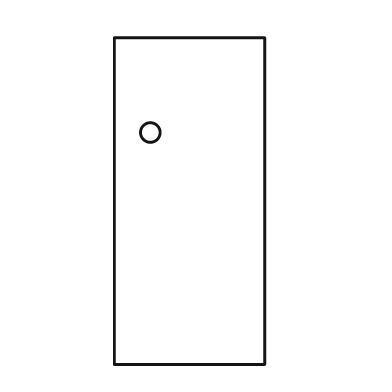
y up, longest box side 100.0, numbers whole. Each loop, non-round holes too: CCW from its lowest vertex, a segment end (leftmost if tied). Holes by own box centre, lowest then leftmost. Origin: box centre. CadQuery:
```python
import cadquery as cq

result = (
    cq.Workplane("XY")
    .moveTo(-23.0, -50.0)
    .lineTo(23.0, -50.0)
    .lineTo(23.0, 50.0)
    .lineTo(-23.0, 50.0)
    .close()
    .moveTo(-12.0, 21.0)
    .circle(3.0)
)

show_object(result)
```